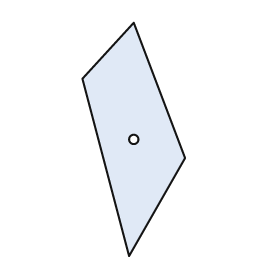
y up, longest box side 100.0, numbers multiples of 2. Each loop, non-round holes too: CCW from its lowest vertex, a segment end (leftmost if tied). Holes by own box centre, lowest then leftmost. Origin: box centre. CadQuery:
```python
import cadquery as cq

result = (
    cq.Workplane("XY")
    .moveTo(-2.0, -50.0)
    .lineTo(22.0, -8.0)
    .lineTo(0.0, 50.0)
    .lineTo(-22.0, 26.0)
    .close()
    .moveTo(0.0, 0.0)
    .circle(2.0)
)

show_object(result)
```